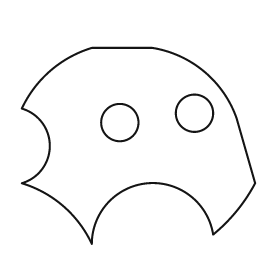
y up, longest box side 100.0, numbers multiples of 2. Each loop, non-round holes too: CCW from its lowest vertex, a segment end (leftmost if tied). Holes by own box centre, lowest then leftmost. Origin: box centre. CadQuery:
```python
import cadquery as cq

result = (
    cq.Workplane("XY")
    .moveTo(-20.0, -42.0)
    .threePointArc((4.0, -16.0), (32.0, -38.0))
    .threePointArc((42.0, -28.0), (50.0, -16.0))
    .lineTo(42.0, 12.0)
    .threePointArc((28.0, 32.0), (6.0, 42.0))
    .lineTo(-20.0, 42.0)
    .threePointArc((-38.0, 32.0), (-50.0, 16.0))
    .threePointArc((-38.0, 0.0), (-50.0, -16.0))
    .threePointArc((-32.0, -26.0), (-20.0, -42.0))
    .close()
    .moveTo(-8.0, 10.0)
    .circle(8.0)
    .moveTo(24.0, 14.0)
    .circle(8.0)
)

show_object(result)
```